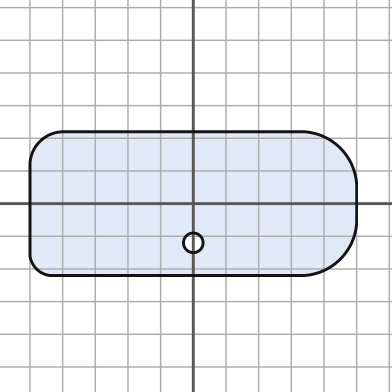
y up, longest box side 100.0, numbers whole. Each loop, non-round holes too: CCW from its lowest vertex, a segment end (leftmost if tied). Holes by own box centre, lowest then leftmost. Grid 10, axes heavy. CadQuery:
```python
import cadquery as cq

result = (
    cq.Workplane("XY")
    .moveTo(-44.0, -22.0)
    .lineTo(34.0, -22.0)
    .threePointArc((45.0, -17.0), (50.0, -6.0))
    .lineTo(50.0, 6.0)
    .threePointArc((45.0, 17.0), (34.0, 22.0))
    .lineTo(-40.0, 22.0)
    .threePointArc((-47.0, 19.0), (-50.0, 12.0))
    .lineTo(-50.0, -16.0)
    .threePointArc((-48.0, -20.0), (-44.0, -22.0))
    .close()
    .moveTo(0.0, -12.0)
    .circle(3.0)
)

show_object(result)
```